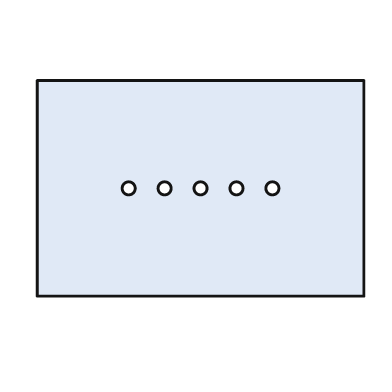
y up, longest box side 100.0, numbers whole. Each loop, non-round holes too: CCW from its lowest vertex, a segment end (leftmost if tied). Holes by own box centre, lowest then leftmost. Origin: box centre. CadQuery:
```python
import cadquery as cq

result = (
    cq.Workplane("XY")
    .moveTo(-50.0, -33.0)
    .lineTo(50.0, -33.0)
    .lineTo(50.0, 33.0)
    .lineTo(-50.0, 33.0)
    .close()
    .moveTo(-22.0, 0.0)
    .circle(2.0)
    .moveTo(-11.0, 0.0)
    .circle(2.0)
    .moveTo(0.0, 0.0)
    .circle(2.0)
    .moveTo(11.0, 0.0)
    .circle(2.0)
    .moveTo(22.0, 0.0)
    .circle(2.0)
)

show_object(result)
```